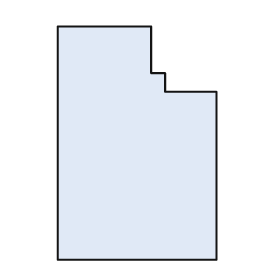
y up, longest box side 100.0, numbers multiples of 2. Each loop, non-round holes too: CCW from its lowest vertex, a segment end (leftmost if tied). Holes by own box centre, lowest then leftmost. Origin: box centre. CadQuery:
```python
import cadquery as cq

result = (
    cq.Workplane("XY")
    .moveTo(-34.0, -50.0)
    .lineTo(34.0, -50.0)
    .lineTo(34.0, 22.0)
    .lineTo(12.0, 22.0)
    .lineTo(12.0, 30.0)
    .lineTo(6.0, 30.0)
    .lineTo(6.0, 50.0)
    .lineTo(-34.0, 50.0)
    .close()
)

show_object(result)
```